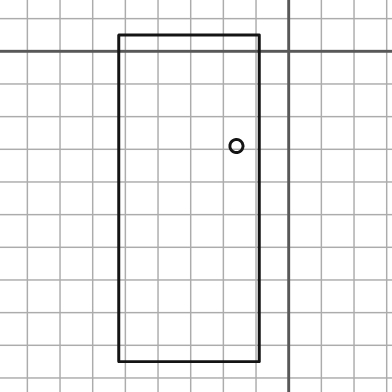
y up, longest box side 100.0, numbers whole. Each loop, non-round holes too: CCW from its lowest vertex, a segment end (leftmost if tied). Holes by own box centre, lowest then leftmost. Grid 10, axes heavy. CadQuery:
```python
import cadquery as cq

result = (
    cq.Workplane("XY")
    .moveTo(-52.0, -95.0)
    .lineTo(-9.0, -95.0)
    .lineTo(-9.0, 5.0)
    .lineTo(-52.0, 5.0)
    .close()
    .moveTo(-16.0, -29.0)
    .circle(2.0)
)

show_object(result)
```